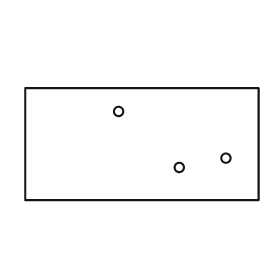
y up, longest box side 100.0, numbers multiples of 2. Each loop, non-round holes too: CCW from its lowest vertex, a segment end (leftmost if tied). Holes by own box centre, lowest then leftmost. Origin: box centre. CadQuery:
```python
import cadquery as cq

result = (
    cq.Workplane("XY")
    .moveTo(-50.0, -24.0)
    .lineTo(50.0, -24.0)
    .lineTo(50.0, 24.0)
    .lineTo(-50.0, 24.0)
    .close()
    .moveTo(16.0, -10.0)
    .circle(2.0)
    .moveTo(36.0, -6.0)
    .circle(2.0)
    .moveTo(-10.0, 14.0)
    .circle(2.0)
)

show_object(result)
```